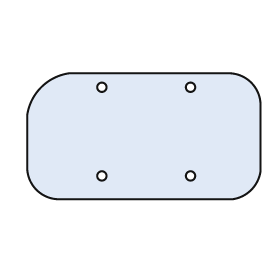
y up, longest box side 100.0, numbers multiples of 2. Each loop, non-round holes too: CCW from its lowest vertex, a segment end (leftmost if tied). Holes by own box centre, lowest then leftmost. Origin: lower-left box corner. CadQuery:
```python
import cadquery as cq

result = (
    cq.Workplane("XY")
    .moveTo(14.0, 0.0)
    .lineTo(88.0, 0.0)
    .threePointArc((96.0, 4.0), (100.0, 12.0))
    .lineTo(100.0, 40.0)
    .threePointArc((96.0, 50.0), (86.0, 54.0))
    .lineTo(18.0, 54.0)
    .threePointArc((6.0, 48.0), (0.0, 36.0))
    .lineTo(0.0, 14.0)
    .threePointArc((4.0, 4.0), (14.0, 0.0))
    .close()
    .moveTo(32.0, 10.0)
    .circle(2.0)
    .moveTo(70.0, 10.0)
    .circle(2.0)
    .moveTo(32.0, 48.0)
    .circle(2.0)
    .moveTo(70.0, 48.0)
    .circle(2.0)
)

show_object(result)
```